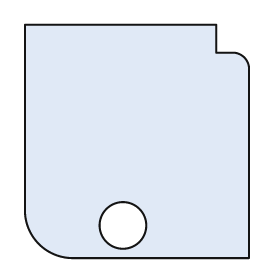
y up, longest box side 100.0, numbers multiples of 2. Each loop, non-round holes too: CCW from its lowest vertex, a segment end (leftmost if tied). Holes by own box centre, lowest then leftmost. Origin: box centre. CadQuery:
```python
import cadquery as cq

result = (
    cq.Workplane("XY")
    .moveTo(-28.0, -50.0)
    .lineTo(48.0, -50.0)
    .lineTo(48.0, 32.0)
    .threePointArc((46.0, 36.0), (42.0, 38.0))
    .lineTo(34.0, 38.0)
    .lineTo(34.0, 50.0)
    .lineTo(-48.0, 50.0)
    .lineTo(-48.0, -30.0)
    .threePointArc((-42.0, -44.0), (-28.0, -50.0))
    .close()
    .moveTo(-6.0, -36.0)
    .circle(10.0)
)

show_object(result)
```